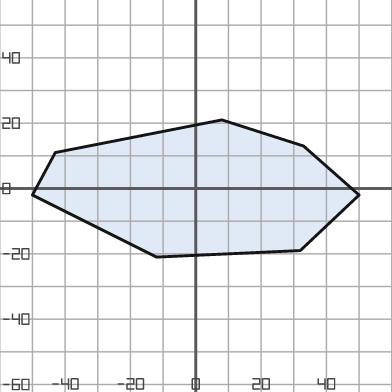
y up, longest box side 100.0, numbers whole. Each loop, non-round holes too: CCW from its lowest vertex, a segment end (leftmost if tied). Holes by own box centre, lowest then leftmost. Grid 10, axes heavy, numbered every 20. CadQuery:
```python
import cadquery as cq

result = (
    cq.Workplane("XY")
    .moveTo(-12.0, -21.0)
    .lineTo(32.0, -19.0)
    .lineTo(50.0, -2.0)
    .lineTo(33.0, 13.0)
    .lineTo(8.0, 21.0)
    .lineTo(-43.0, 11.0)
    .lineTo(-50.0, -2.0)
    .close()
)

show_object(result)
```